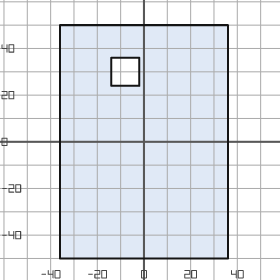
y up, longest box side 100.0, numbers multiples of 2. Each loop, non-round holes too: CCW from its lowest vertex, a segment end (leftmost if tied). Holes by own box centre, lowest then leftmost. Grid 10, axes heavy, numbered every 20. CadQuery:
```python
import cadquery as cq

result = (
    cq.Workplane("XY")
    .moveTo(-36.0, -50.0)
    .lineTo(36.0, -50.0)
    .lineTo(36.0, 50.0)
    .lineTo(-36.0, 50.0)
    .close()
    .moveTo(-14.0, 24.0)
    .lineTo(-2.0, 24.0)
    .lineTo(-2.0, 36.0)
    .lineTo(-14.0, 36.0)
    .close()
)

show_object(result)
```